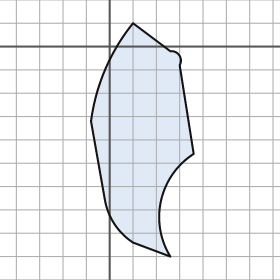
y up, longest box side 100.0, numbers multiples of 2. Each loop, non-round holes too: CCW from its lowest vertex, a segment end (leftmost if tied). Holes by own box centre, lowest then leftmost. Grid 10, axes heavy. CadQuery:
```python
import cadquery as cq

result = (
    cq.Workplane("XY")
    .moveTo(26.0, -90.0)
    .threePointArc((22.0, -66.0), (36.0, -46.0))
    .lineTo(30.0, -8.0)
    .threePointArc((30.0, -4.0), (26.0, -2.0))
    .lineTo(10.0, 10.0)
    .threePointArc((-2.0, -10.0), (-8.0, -32.0))
    .lineTo(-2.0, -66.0)
    .threePointArc((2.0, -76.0), (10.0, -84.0))
    .close()
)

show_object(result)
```